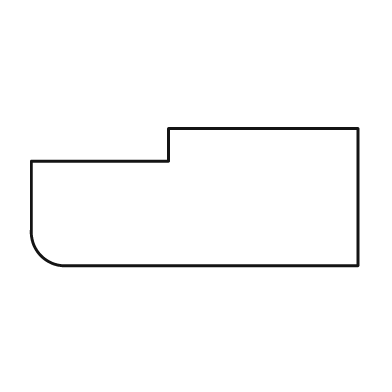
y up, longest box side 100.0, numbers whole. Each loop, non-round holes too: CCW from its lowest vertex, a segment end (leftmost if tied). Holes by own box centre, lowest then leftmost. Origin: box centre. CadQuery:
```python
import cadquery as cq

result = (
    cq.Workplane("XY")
    .moveTo(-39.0, -21.0)
    .lineTo(50.0, -21.0)
    .lineTo(50.0, 21.0)
    .lineTo(-8.0, 21.0)
    .lineTo(-8.0, 11.0)
    .lineTo(-50.0, 11.0)
    .lineTo(-50.0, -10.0)
    .threePointArc((-47.0, -18.0), (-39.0, -21.0))
    .close()
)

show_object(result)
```